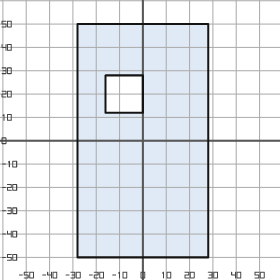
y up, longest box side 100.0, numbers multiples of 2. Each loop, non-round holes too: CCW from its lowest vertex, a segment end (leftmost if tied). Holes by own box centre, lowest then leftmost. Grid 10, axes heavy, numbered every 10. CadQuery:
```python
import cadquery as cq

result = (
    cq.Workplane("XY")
    .moveTo(-28.0, -50.0)
    .lineTo(28.0, -50.0)
    .lineTo(28.0, 50.0)
    .lineTo(-28.0, 50.0)
    .close()
    .moveTo(-16.0, 12.0)
    .lineTo(0.0, 12.0)
    .lineTo(0.0, 28.0)
    .lineTo(-16.0, 28.0)
    .close()
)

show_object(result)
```